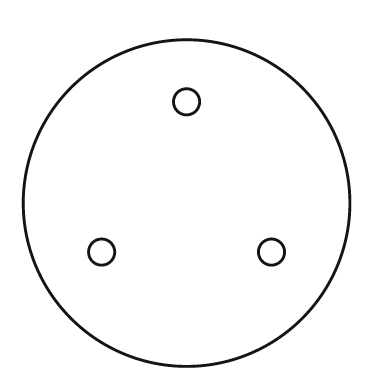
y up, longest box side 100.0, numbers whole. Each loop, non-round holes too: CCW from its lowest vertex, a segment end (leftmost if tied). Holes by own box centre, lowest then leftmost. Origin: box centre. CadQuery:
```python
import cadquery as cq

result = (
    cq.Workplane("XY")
    .moveTo(0.0, 0.0)
    .circle(50.0)
    .moveTo(-26.0, -15.0)
    .circle(4.0)
    .moveTo(26.0, -15.0)
    .circle(4.0)
    .moveTo(0.0, 31.0)
    .circle(4.0)
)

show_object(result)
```